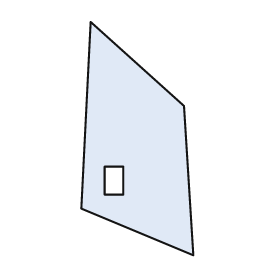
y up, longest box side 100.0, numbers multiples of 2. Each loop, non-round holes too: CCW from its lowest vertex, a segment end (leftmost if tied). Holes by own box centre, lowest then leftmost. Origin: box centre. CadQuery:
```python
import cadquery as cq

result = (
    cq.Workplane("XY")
    .moveTo(24.0, -50.0)
    .lineTo(20.0, 14.0)
    .lineTo(-20.0, 50.0)
    .lineTo(-24.0, -30.0)
    .close()
    .moveTo(-14.0, -24.0)
    .lineTo(-6.0, -24.0)
    .lineTo(-6.0, -12.0)
    .lineTo(-14.0, -12.0)
    .close()
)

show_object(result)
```